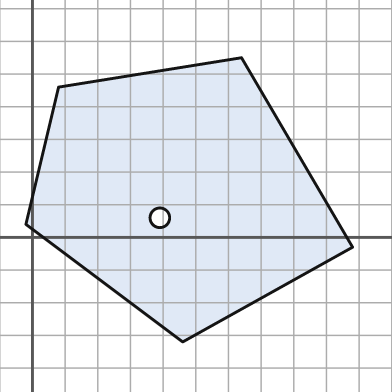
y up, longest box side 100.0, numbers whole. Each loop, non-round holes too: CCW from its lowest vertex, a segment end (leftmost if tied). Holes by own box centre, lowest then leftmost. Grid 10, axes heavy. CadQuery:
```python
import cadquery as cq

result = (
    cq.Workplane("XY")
    .moveTo(46.0, -32.0)
    .lineTo(98.0, -3.0)
    .lineTo(64.0, 55.0)
    .lineTo(8.0, 46.0)
    .lineTo(-2.0, 4.0)
    .close()
    .moveTo(39.0, 6.0)
    .circle(3.0)
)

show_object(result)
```